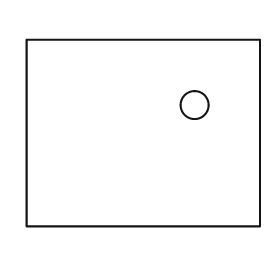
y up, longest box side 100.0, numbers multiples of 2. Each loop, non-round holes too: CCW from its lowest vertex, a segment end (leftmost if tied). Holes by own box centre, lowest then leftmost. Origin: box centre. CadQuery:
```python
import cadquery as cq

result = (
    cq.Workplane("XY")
    .moveTo(-50.0, -40.0)
    .lineTo(50.0, -40.0)
    .lineTo(50.0, 40.0)
    .lineTo(-50.0, 40.0)
    .close()
    .moveTo(22.0, 12.0)
    .circle(6.0)
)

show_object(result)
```